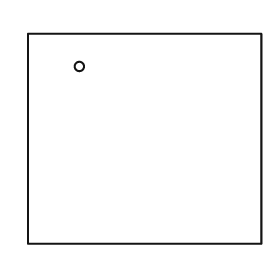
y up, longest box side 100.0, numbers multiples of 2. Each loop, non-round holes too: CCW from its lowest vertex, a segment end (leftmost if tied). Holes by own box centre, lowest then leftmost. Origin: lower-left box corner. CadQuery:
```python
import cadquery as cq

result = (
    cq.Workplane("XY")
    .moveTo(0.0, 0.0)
    .lineTo(100.0, 0.0)
    .lineTo(100.0, 90.0)
    .lineTo(0.0, 90.0)
    .close()
    .moveTo(22.0, 76.0)
    .circle(2.0)
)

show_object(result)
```